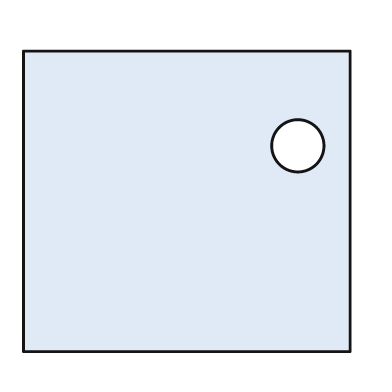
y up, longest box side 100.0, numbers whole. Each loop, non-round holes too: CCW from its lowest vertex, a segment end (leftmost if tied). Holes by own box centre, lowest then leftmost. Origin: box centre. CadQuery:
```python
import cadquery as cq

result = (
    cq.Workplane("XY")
    .moveTo(-50.0, -46.0)
    .lineTo(50.0, -46.0)
    .lineTo(50.0, 46.0)
    .lineTo(-50.0, 46.0)
    .close()
    .moveTo(34.0, 17.0)
    .circle(8.0)
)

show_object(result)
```